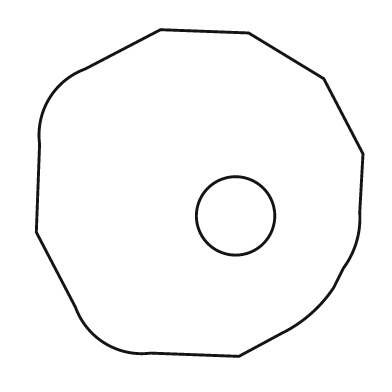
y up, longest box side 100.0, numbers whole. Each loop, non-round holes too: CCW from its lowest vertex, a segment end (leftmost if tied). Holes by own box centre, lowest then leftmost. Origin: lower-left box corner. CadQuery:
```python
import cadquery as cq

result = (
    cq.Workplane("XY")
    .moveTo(62.0, 0.0)
    .lineTo(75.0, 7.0)
    .threePointArc((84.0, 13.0), (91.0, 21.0))
    .lineTo(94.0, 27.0)
    .threePointArc((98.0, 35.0), (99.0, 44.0))
    .lineTo(100.0, 62.0)
    .lineTo(88.0, 85.0)
    .lineTo(65.0, 99.0)
    .lineTo(38.0, 100.0)
    .lineTo(15.0, 88.0)
    .threePointArc((4.0, 79.0), (1.0, 65.0))
    .lineTo(0.0, 38.0)
    .lineTo(12.0, 15.0)
    .threePointArc((21.0, 4.0), (35.0, 1.0))
    .close()
    .moveTo(61.0, 43.0)
    .circle(12.0)
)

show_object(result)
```